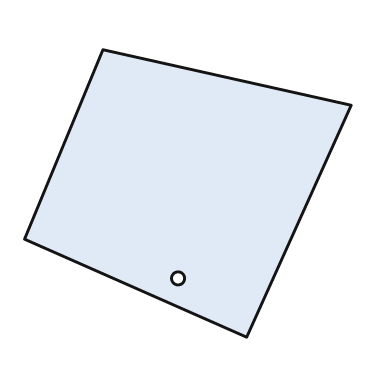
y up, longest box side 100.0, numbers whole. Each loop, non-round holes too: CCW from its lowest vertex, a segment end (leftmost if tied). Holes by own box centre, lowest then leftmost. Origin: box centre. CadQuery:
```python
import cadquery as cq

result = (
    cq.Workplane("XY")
    .moveTo(18.0, -44.0)
    .lineTo(50.0, 27.0)
    .lineTo(-26.0, 44.0)
    .lineTo(-50.0, -14.0)
    .close()
    .moveTo(-3.0, -26.0)
    .circle(2.0)
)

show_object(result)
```